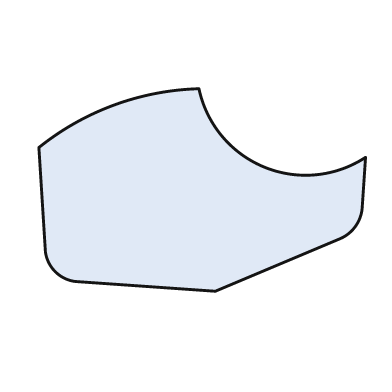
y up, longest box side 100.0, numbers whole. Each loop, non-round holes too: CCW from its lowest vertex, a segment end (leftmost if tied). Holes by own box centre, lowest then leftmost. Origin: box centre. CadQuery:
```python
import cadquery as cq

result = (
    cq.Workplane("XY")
    .moveTo(4.0, -31.0)
    .lineTo(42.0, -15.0)
    .threePointArc((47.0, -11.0), (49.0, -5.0))
    .lineTo(50.0, 10.0)
    .threePointArc((19.0, 7.0), (-1.0, 31.0))
    .threePointArc((-27.0, 26.0), (-50.0, 13.0))
    .lineTo(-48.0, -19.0)
    .threePointArc((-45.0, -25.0), (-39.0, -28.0))
    .close()
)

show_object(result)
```